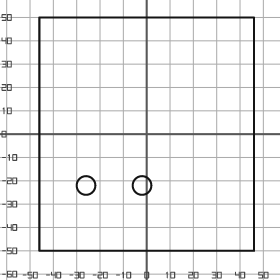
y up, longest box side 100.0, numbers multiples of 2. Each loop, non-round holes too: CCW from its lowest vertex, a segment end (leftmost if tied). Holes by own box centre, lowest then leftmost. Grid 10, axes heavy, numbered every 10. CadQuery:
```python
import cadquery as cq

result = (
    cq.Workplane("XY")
    .moveTo(-46.0, -50.0)
    .lineTo(46.0, -50.0)
    .lineTo(46.0, 50.0)
    .lineTo(-46.0, 50.0)
    .close()
    .moveTo(-26.0, -22.0)
    .circle(4.0)
    .moveTo(-2.0, -22.0)
    .circle(4.0)
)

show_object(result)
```